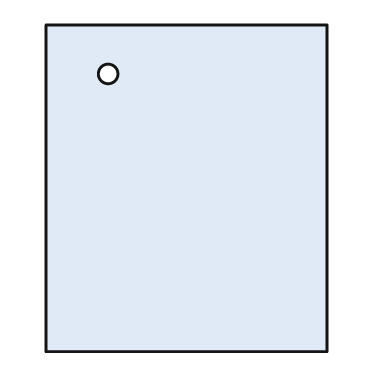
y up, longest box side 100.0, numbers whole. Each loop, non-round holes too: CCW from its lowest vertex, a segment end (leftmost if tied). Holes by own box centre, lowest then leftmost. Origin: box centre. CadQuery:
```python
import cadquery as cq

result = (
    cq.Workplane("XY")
    .moveTo(-43.0, -50.0)
    .lineTo(43.0, -50.0)
    .lineTo(43.0, 50.0)
    .lineTo(-43.0, 50.0)
    .close()
    .moveTo(-24.0, 35.0)
    .circle(3.0)
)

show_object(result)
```